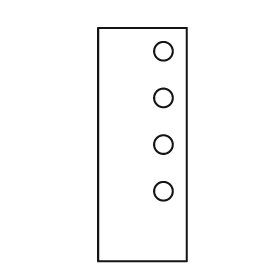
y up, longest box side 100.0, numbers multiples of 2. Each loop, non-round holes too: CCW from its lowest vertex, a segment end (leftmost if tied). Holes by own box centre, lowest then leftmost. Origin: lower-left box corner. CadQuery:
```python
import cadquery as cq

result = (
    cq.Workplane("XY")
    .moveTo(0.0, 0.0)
    .lineTo(38.0, 0.0)
    .lineTo(38.0, 100.0)
    .lineTo(0.0, 100.0)
    .close()
    .moveTo(28.0, 30.0)
    .circle(4.0)
    .moveTo(28.0, 50.0)
    .circle(4.0)
    .moveTo(28.0, 70.0)
    .circle(4.0)
    .moveTo(28.0, 90.0)
    .circle(4.0)
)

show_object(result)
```